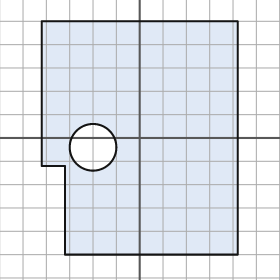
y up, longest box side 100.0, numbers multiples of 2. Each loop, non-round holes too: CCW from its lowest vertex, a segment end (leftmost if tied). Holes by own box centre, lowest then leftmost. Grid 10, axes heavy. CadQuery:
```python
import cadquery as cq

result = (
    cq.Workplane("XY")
    .moveTo(-32.0, -50.0)
    .lineTo(42.0, -50.0)
    .lineTo(42.0, 50.0)
    .lineTo(-42.0, 50.0)
    .lineTo(-42.0, -12.0)
    .lineTo(-32.0, -12.0)
    .close()
    .moveTo(-20.0, -4.0)
    .circle(10.0)
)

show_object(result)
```